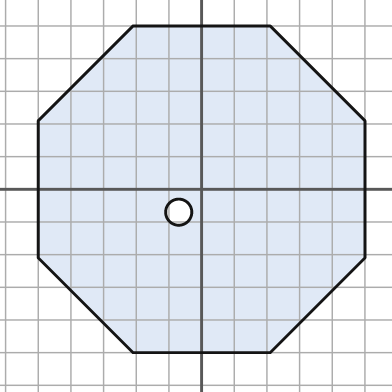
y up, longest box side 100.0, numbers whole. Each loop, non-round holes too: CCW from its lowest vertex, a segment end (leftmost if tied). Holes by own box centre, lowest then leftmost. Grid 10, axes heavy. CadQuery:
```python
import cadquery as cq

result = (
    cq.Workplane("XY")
    .moveTo(-21.0, -50.0)
    .lineTo(21.0, -50.0)
    .lineTo(50.0, -21.0)
    .lineTo(50.0, 21.0)
    .lineTo(21.0, 50.0)
    .lineTo(-21.0, 50.0)
    .lineTo(-50.0, 21.0)
    .lineTo(-50.0, -21.0)
    .close()
    .moveTo(-7.0, -7.0)
    .circle(4.0)
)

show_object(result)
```